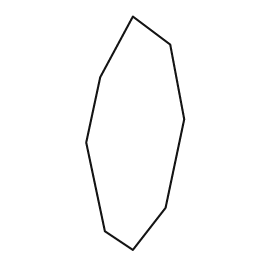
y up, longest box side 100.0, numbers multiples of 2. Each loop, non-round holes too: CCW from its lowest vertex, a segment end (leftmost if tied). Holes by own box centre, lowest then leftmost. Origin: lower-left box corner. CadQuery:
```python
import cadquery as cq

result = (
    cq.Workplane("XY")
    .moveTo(20.0, 0.0)
    .lineTo(34.0, 18.0)
    .lineTo(42.0, 56.0)
    .lineTo(36.0, 88.0)
    .lineTo(20.0, 100.0)
    .lineTo(6.0, 74.0)
    .lineTo(0.0, 46.0)
    .lineTo(8.0, 8.0)
    .close()
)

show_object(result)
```